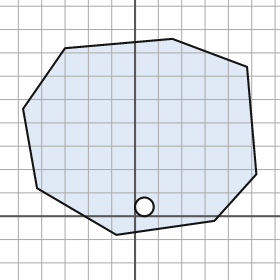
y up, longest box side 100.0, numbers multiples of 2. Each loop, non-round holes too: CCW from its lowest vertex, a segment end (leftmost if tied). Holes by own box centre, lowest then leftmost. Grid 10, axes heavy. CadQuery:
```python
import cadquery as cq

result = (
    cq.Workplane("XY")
    .moveTo(-8.0, -8.0)
    .lineTo(34.0, -2.0)
    .lineTo(52.0, 18.0)
    .lineTo(48.0, 64.0)
    .lineTo(16.0, 76.0)
    .lineTo(-30.0, 72.0)
    .lineTo(-48.0, 46.0)
    .lineTo(-42.0, 12.0)
    .close()
    .moveTo(4.0, 4.0)
    .circle(4.0)
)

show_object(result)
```